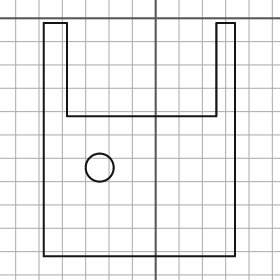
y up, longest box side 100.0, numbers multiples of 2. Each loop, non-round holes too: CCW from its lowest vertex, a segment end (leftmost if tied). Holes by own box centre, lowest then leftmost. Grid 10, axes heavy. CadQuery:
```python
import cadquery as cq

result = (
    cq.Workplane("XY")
    .moveTo(-48.0, -102.0)
    .lineTo(34.0, -102.0)
    .lineTo(34.0, -2.0)
    .lineTo(26.0, -2.0)
    .lineTo(26.0, -42.0)
    .lineTo(-38.0, -42.0)
    .lineTo(-38.0, -2.0)
    .lineTo(-48.0, -2.0)
    .close()
    .moveTo(-24.0, -64.0)
    .circle(6.0)
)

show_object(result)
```